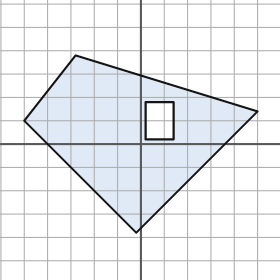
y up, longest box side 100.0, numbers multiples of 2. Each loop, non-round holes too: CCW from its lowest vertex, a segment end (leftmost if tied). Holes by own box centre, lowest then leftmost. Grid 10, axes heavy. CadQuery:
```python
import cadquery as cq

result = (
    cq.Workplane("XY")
    .moveTo(-2.0, -38.0)
    .lineTo(50.0, 14.0)
    .lineTo(-28.0, 38.0)
    .lineTo(-50.0, 10.0)
    .close()
    .moveTo(2.0, 2.0)
    .lineTo(14.0, 2.0)
    .lineTo(14.0, 18.0)
    .lineTo(2.0, 18.0)
    .close()
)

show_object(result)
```